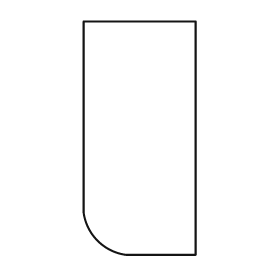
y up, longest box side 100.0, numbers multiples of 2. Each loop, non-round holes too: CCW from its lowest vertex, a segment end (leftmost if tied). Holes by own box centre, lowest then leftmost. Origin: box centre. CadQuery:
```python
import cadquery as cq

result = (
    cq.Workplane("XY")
    .moveTo(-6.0, -50.0)
    .lineTo(24.0, -50.0)
    .lineTo(24.0, 50.0)
    .lineTo(-24.0, 50.0)
    .lineTo(-24.0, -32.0)
    .threePointArc((-18.0, -44.0), (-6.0, -50.0))
    .close()
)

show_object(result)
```